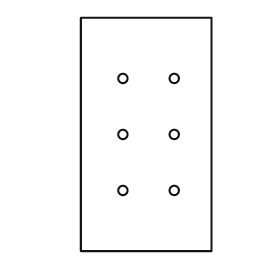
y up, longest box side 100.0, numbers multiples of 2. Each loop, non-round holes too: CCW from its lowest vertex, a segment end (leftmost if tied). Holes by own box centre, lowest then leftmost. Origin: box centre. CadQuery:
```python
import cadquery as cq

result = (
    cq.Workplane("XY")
    .moveTo(-28.0, -50.0)
    .lineTo(28.0, -50.0)
    .lineTo(28.0, 50.0)
    .lineTo(-28.0, 50.0)
    .close()
    .moveTo(-10.0, -24.0)
    .circle(2.0)
    .moveTo(12.0, -24.0)
    .circle(2.0)
    .moveTo(-10.0, 0.0)
    .circle(2.0)
    .moveTo(12.0, 0.0)
    .circle(2.0)
    .moveTo(-10.0, 24.0)
    .circle(2.0)
    .moveTo(12.0, 24.0)
    .circle(2.0)
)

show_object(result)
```